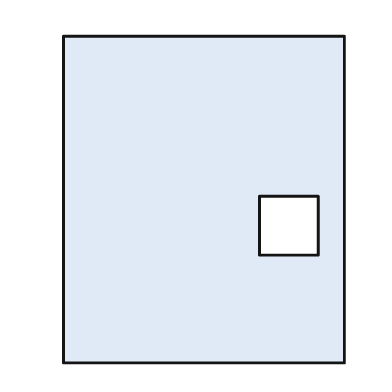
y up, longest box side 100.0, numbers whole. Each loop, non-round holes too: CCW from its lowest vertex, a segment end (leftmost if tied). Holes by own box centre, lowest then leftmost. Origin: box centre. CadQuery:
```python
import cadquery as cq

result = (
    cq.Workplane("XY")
    .moveTo(-43.0, -50.0)
    .lineTo(43.0, -50.0)
    .lineTo(43.0, 50.0)
    .lineTo(-43.0, 50.0)
    .close()
    .moveTo(17.0, -17.0)
    .lineTo(35.0, -17.0)
    .lineTo(35.0, 1.0)
    .lineTo(17.0, 1.0)
    .close()
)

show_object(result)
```